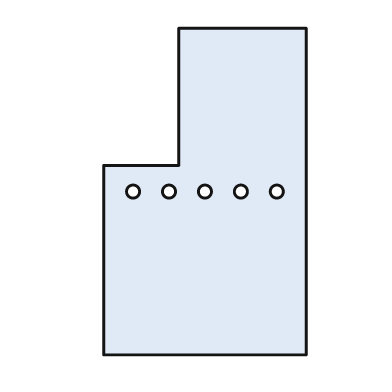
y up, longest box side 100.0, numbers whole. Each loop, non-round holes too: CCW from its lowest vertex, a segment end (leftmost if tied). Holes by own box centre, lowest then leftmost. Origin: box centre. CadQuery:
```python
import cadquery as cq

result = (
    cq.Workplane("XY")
    .moveTo(-31.0, -50.0)
    .lineTo(31.0, -50.0)
    .lineTo(31.0, 50.0)
    .lineTo(-8.0, 50.0)
    .lineTo(-8.0, 8.0)
    .lineTo(-31.0, 8.0)
    .close()
    .moveTo(-22.0, 0.0)
    .circle(2.0)
    .moveTo(-11.0, 0.0)
    .circle(2.0)
    .moveTo(0.0, 0.0)
    .circle(2.0)
    .moveTo(11.0, 0.0)
    .circle(2.0)
    .moveTo(22.0, 0.0)
    .circle(2.0)
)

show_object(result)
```